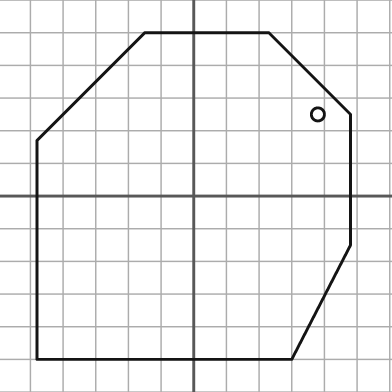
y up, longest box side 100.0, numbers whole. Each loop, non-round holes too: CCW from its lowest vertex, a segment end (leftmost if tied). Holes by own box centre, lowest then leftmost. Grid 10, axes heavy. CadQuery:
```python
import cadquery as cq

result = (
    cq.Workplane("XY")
    .moveTo(-48.0, -50.0)
    .lineTo(30.0, -50.0)
    .lineTo(48.0, -15.0)
    .lineTo(48.0, 25.0)
    .lineTo(23.0, 50.0)
    .lineTo(-15.0, 50.0)
    .lineTo(-48.0, 17.0)
    .close()
    .moveTo(38.0, 25.0)
    .circle(2.0)
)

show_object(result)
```